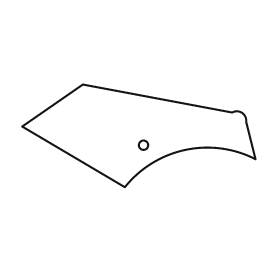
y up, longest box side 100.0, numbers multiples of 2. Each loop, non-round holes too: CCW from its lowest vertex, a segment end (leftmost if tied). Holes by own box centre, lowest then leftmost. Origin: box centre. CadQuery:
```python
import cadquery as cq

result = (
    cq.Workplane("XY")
    .moveTo(-6.0, -22.0)
    .threePointArc((20.0, -6.0), (50.0, -10.0))
    .lineTo(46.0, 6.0)
    .threePointArc((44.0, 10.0), (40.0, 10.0))
    .lineTo(-24.0, 22.0)
    .lineTo(-50.0, 4.0)
    .close()
    .moveTo(2.0, -4.0)
    .circle(2.0)
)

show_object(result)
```